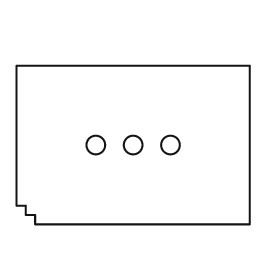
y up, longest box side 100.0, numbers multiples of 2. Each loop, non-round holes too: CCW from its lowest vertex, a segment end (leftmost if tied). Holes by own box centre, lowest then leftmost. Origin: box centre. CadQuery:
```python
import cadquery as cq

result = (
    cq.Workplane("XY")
    .moveTo(-42.0, -34.0)
    .lineTo(50.0, -34.0)
    .lineTo(50.0, 34.0)
    .lineTo(-50.0, 34.0)
    .lineTo(-50.0, -26.0)
    .lineTo(-46.0, -26.0)
    .lineTo(-46.0, -30.0)
    .lineTo(-42.0, -30.0)
    .close()
    .moveTo(-16.0, 0.0)
    .circle(4.0)
    .moveTo(0.0, 0.0)
    .circle(4.0)
    .moveTo(16.0, 0.0)
    .circle(4.0)
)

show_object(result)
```